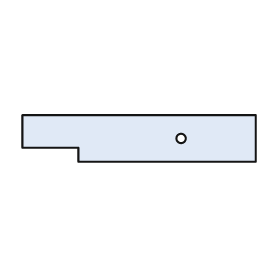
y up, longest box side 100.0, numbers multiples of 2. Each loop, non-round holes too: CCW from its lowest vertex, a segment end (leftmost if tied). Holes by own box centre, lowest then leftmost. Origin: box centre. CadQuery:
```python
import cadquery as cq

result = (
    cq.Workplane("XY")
    .moveTo(-26.0, -10.0)
    .lineTo(50.0, -10.0)
    .lineTo(50.0, 10.0)
    .lineTo(-50.0, 10.0)
    .lineTo(-50.0, -4.0)
    .lineTo(-26.0, -4.0)
    .close()
    .moveTo(18.0, 0.0)
    .circle(2.0)
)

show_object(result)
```